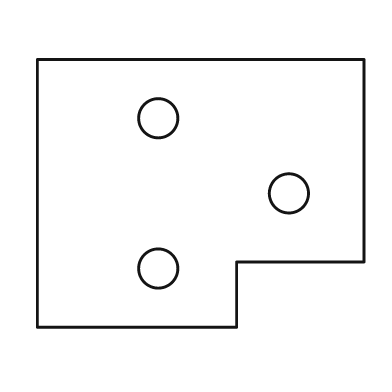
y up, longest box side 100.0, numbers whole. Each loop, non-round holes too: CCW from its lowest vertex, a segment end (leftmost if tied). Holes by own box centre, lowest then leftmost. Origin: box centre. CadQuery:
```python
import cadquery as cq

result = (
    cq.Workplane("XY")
    .moveTo(-50.0, -41.0)
    .lineTo(11.0, -41.0)
    .lineTo(11.0, -21.0)
    .lineTo(50.0, -21.0)
    .lineTo(50.0, 41.0)
    .lineTo(-50.0, 41.0)
    .close()
    .moveTo(-13.0, -23.0)
    .circle(6.0)
    .moveTo(27.0, 0.0)
    .circle(6.0)
    .moveTo(-13.0, 23.0)
    .circle(6.0)
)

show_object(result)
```